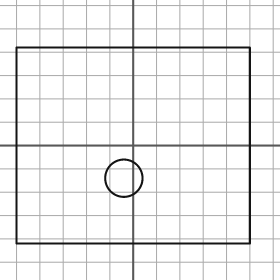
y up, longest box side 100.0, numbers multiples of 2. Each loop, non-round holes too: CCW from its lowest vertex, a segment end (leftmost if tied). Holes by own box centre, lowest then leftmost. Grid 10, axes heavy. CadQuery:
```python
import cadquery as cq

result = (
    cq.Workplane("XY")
    .moveTo(-50.0, -42.0)
    .lineTo(50.0, -42.0)
    .lineTo(50.0, 42.0)
    .lineTo(-50.0, 42.0)
    .close()
    .moveTo(-4.0, -14.0)
    .circle(8.0)
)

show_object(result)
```